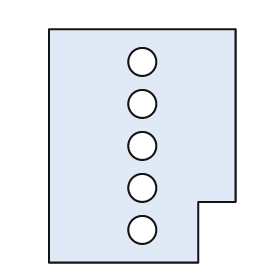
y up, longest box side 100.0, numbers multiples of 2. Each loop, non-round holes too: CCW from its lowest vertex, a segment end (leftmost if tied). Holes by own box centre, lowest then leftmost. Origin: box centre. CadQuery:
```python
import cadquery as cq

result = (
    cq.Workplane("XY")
    .moveTo(-40.0, -50.0)
    .lineTo(24.0, -50.0)
    .lineTo(24.0, -24.0)
    .lineTo(40.0, -24.0)
    .lineTo(40.0, 50.0)
    .lineTo(-40.0, 50.0)
    .close()
    .moveTo(0.0, -36.0)
    .circle(6.0)
    .moveTo(0.0, -18.0)
    .circle(6.0)
    .moveTo(0.0, 0.0)
    .circle(6.0)
    .moveTo(0.0, 18.0)
    .circle(6.0)
    .moveTo(0.0, 36.0)
    .circle(6.0)
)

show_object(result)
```